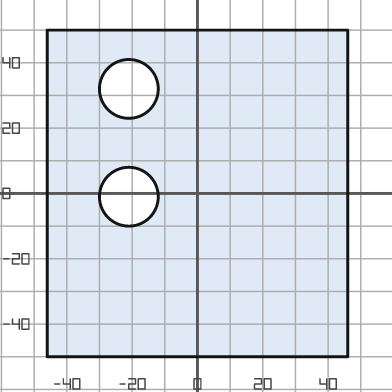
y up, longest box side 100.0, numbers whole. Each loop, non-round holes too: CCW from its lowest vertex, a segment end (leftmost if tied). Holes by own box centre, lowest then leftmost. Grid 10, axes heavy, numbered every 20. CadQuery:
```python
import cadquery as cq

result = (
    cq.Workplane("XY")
    .moveTo(-46.0, -50.0)
    .lineTo(46.0, -50.0)
    .lineTo(46.0, 50.0)
    .lineTo(-46.0, 50.0)
    .close()
    .moveTo(-21.0, -1.0)
    .circle(9.0)
    .moveTo(-21.0, 32.0)
    .circle(9.0)
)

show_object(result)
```